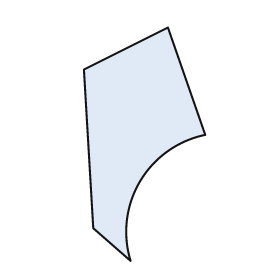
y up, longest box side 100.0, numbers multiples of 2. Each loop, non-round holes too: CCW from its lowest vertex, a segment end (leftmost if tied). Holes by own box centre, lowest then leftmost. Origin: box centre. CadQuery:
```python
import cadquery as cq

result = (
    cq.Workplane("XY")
    .moveTo(-6.0, -50.0)
    .threePointArc((-2.0, -16.0), (26.0, 4.0))
    .lineTo(10.0, 50.0)
    .lineTo(-26.0, 32.0)
    .lineTo(-22.0, -36.0)
    .close()
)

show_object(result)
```